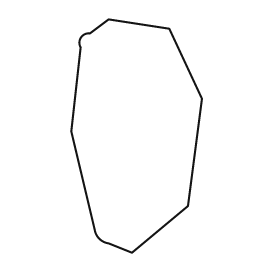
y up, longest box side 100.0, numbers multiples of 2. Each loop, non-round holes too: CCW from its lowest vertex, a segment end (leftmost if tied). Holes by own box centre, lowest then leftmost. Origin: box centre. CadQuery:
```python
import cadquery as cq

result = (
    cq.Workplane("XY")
    .moveTo(-2.0, -50.0)
    .lineTo(22.0, -30.0)
    .lineTo(28.0, 16.0)
    .lineTo(14.0, 46.0)
    .lineTo(-12.0, 50.0)
    .lineTo(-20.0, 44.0)
    .threePointArc((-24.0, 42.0), (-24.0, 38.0))
    .lineTo(-28.0, 2.0)
    .lineTo(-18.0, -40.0)
    .threePointArc((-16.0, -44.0), (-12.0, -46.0))
    .close()
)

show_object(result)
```